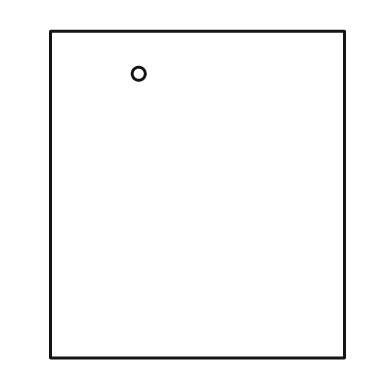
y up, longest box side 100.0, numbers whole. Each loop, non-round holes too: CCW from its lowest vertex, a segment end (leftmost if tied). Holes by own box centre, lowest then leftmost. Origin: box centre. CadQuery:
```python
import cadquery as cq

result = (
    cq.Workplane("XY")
    .moveTo(-45.0, -50.0)
    .lineTo(45.0, -50.0)
    .lineTo(45.0, 50.0)
    .lineTo(-45.0, 50.0)
    .close()
    .moveTo(-18.0, 37.0)
    .circle(2.0)
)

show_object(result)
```